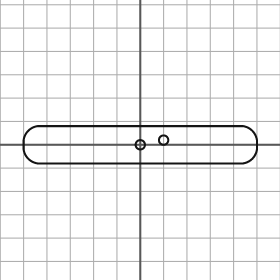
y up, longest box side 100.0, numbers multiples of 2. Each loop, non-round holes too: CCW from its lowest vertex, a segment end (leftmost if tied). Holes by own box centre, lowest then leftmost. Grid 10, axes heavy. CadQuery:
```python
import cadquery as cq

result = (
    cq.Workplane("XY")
    .moveTo(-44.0, -8.0)
    .lineTo(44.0, -8.0)
    .threePointArc((48.0, -6.0), (50.0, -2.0))
    .lineTo(50.0, 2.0)
    .threePointArc((48.0, 6.0), (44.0, 8.0))
    .lineTo(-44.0, 8.0)
    .threePointArc((-48.0, 6.0), (-50.0, 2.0))
    .lineTo(-50.0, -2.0)
    .threePointArc((-48.0, -6.0), (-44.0, -8.0))
    .close()
    .moveTo(0.0, 0.0)
    .circle(2.0)
    .moveTo(10.0, 2.0)
    .circle(2.0)
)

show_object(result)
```